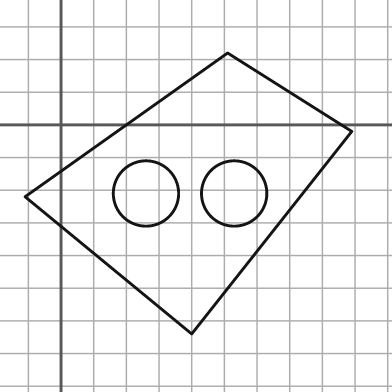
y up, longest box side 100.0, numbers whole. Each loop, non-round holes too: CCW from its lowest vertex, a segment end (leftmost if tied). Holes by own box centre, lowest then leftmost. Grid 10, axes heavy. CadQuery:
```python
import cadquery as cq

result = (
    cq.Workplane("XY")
    .moveTo(40.0, -64.0)
    .lineTo(89.0, -2.0)
    .lineTo(51.0, 22.0)
    .lineTo(-11.0, -22.0)
    .close()
    .moveTo(26.0, -21.0)
    .circle(10.0)
    .moveTo(53.0, -21.0)
    .circle(10.0)
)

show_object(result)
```